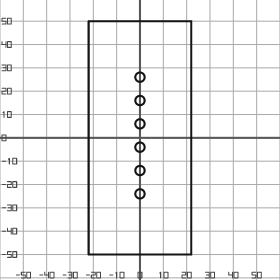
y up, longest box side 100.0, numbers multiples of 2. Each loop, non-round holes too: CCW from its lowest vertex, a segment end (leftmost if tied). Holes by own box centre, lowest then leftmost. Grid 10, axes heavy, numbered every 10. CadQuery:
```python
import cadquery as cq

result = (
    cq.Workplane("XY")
    .moveTo(-22.0, -50.0)
    .lineTo(22.0, -50.0)
    .lineTo(22.0, 50.0)
    .lineTo(-22.0, 50.0)
    .close()
    .moveTo(0.0, -24.0)
    .circle(2.0)
    .moveTo(0.0, -14.0)
    .circle(2.0)
    .moveTo(0.0, -4.0)
    .circle(2.0)
    .moveTo(0.0, 6.0)
    .circle(2.0)
    .moveTo(0.0, 16.0)
    .circle(2.0)
    .moveTo(0.0, 26.0)
    .circle(2.0)
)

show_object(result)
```